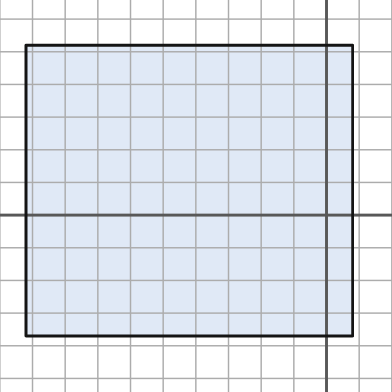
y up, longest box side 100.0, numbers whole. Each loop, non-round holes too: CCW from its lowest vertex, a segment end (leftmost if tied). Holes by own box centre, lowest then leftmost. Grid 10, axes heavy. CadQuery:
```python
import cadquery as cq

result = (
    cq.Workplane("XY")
    .moveTo(-92.0, -37.0)
    .lineTo(8.0, -37.0)
    .lineTo(8.0, 52.0)
    .lineTo(-92.0, 52.0)
    .close()
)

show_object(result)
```